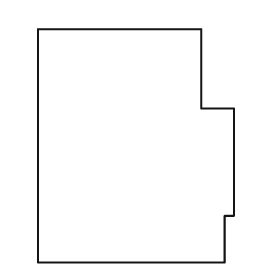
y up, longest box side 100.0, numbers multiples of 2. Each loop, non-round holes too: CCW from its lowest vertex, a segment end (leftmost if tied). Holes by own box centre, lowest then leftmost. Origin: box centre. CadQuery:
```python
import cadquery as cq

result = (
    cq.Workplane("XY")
    .moveTo(-42.0, -50.0)
    .lineTo(38.0, -50.0)
    .lineTo(38.0, -30.0)
    .lineTo(42.0, -30.0)
    .lineTo(42.0, 16.0)
    .lineTo(28.0, 16.0)
    .lineTo(28.0, 50.0)
    .lineTo(-42.0, 50.0)
    .close()
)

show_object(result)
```